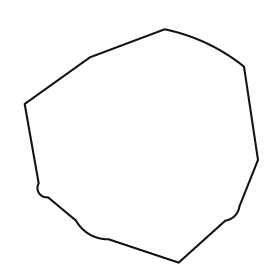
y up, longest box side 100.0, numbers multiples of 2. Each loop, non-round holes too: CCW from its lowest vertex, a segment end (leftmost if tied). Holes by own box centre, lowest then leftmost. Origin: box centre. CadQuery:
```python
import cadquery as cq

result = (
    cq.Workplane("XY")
    .moveTo(16.0, -50.0)
    .lineTo(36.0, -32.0)
    .threePointArc((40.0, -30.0), (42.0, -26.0))
    .lineTo(50.0, -6.0)
    .lineTo(44.0, 34.0)
    .threePointArc((28.0, 44.0), (10.0, 50.0))
    .lineTo(-22.0, 38.0)
    .lineTo(-50.0, 18.0)
    .lineTo(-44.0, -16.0)
    .threePointArc((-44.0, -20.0), (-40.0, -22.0))
    .lineTo(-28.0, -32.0)
    .threePointArc((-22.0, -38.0), (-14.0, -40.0))
    .close()
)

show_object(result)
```